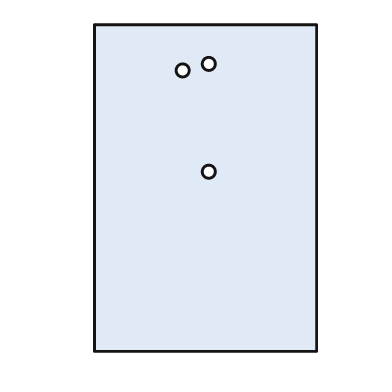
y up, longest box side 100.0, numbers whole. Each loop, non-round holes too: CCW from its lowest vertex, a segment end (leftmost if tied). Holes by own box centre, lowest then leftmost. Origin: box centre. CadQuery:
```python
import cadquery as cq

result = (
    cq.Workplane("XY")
    .moveTo(-34.0, -50.0)
    .lineTo(34.0, -50.0)
    .lineTo(34.0, 50.0)
    .lineTo(-34.0, 50.0)
    .close()
    .moveTo(1.0, 5.0)
    .circle(2.0)
    .moveTo(-7.0, 36.0)
    .circle(2.0)
    .moveTo(1.0, 38.0)
    .circle(2.0)
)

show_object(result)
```